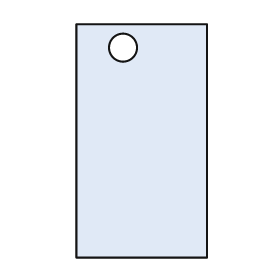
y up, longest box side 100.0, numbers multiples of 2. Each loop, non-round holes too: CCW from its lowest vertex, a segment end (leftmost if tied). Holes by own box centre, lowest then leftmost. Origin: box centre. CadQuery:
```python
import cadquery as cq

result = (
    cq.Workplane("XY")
    .moveTo(-28.0, -50.0)
    .lineTo(28.0, -50.0)
    .lineTo(28.0, 50.0)
    .lineTo(-28.0, 50.0)
    .close()
    .moveTo(-8.0, 40.0)
    .circle(6.0)
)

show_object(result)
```